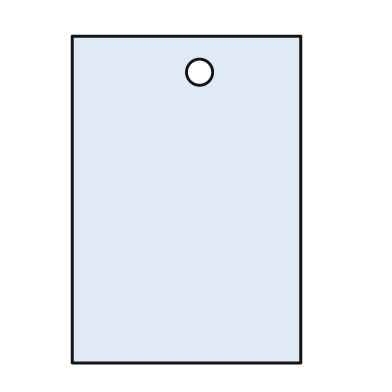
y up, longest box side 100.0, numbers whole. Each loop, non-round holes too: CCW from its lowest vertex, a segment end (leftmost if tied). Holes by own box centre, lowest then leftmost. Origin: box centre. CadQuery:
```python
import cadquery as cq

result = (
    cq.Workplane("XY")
    .moveTo(-35.0, -50.0)
    .lineTo(35.0, -50.0)
    .lineTo(35.0, 50.0)
    .lineTo(-35.0, 50.0)
    .close()
    .moveTo(4.0, 39.0)
    .circle(4.0)
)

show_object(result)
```